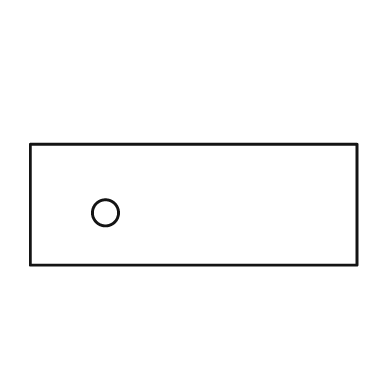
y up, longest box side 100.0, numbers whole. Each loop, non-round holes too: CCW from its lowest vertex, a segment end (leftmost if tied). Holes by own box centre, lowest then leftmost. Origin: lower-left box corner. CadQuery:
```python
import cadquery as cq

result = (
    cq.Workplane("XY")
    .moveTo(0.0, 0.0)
    .lineTo(100.0, 0.0)
    .lineTo(100.0, 37.0)
    .lineTo(0.0, 37.0)
    .close()
    .moveTo(23.0, 16.0)
    .circle(4.0)
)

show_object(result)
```